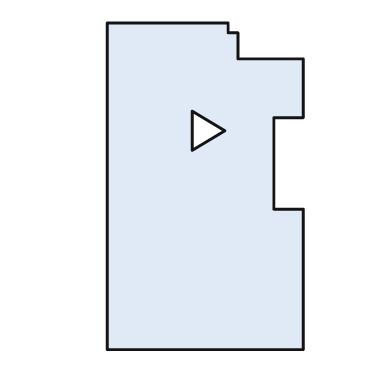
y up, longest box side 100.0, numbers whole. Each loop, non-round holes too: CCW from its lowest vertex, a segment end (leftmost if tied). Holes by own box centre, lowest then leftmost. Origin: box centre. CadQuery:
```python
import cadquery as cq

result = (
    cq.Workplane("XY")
    .moveTo(-30.0, -50.0)
    .lineTo(30.0, -50.0)
    .lineTo(30.0, -7.0)
    .lineTo(21.0, -7.0)
    .lineTo(21.0, 21.0)
    .lineTo(30.0, 21.0)
    .lineTo(30.0, 39.0)
    .lineTo(10.0, 39.0)
    .lineTo(10.0, 47.0)
    .lineTo(7.0, 47.0)
    .lineTo(7.0, 50.0)
    .lineTo(-30.0, 50.0)
    .close()
    .moveTo(-4.0, 11.0)
    .lineTo(6.0, 17.0)
    .lineTo(-4.0, 23.0)
    .close()
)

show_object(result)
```